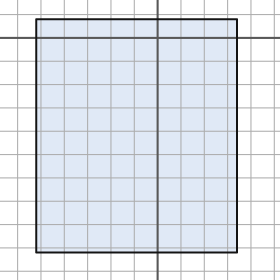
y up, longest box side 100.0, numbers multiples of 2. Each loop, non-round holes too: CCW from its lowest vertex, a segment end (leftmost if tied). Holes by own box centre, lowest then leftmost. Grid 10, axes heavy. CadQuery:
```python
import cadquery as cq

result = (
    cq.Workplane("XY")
    .moveTo(-52.0, -92.0)
    .lineTo(34.0, -92.0)
    .lineTo(34.0, 8.0)
    .lineTo(-52.0, 8.0)
    .close()
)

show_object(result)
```